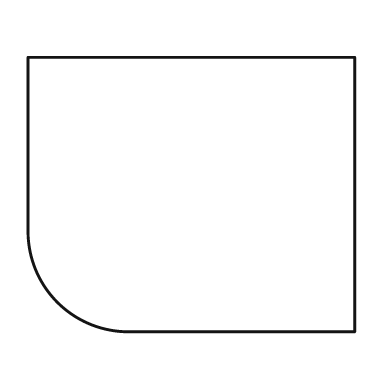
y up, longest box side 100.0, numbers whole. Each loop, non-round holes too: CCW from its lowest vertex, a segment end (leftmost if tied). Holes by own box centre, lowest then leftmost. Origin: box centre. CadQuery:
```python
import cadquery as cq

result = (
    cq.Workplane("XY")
    .moveTo(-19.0, -42.0)
    .lineTo(50.0, -42.0)
    .lineTo(50.0, 42.0)
    .lineTo(-50.0, 42.0)
    .lineTo(-50.0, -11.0)
    .threePointArc((-41.0, -33.0), (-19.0, -42.0))
    .close()
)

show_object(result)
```